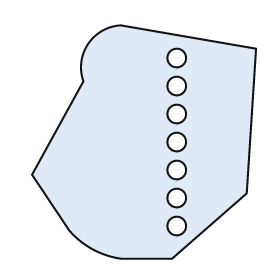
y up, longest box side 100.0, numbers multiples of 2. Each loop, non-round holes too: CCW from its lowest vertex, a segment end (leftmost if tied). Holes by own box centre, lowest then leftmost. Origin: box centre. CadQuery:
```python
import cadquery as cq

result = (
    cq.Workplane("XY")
    .moveTo(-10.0, -50.0)
    .lineTo(12.0, -50.0)
    .lineTo(44.0, -22.0)
    .lineTo(48.0, 40.0)
    .lineTo(-10.0, 50.0)
    .threePointArc((-24.0, 42.0), (-26.0, 26.0))
    .lineTo(-48.0, -14.0)
    .lineTo(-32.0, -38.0)
    .threePointArc((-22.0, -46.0), (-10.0, -50.0))
    .close()
    .moveTo(14.0, -36.0)
    .circle(4.0)
    .moveTo(14.0, -24.0)
    .circle(4.0)
    .moveTo(14.0, -12.0)
    .circle(4.0)
    .moveTo(14.0, 0.0)
    .circle(4.0)
    .moveTo(14.0, 12.0)
    .circle(4.0)
    .moveTo(14.0, 24.0)
    .circle(4.0)
    .moveTo(14.0, 36.0)
    .circle(4.0)
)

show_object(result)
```